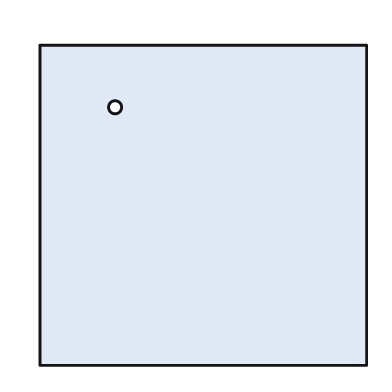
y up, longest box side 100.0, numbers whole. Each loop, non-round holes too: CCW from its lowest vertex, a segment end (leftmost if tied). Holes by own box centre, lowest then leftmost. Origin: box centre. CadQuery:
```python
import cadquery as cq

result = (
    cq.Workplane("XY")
    .moveTo(-50.0, -49.0)
    .lineTo(50.0, -49.0)
    .lineTo(50.0, 49.0)
    .lineTo(-50.0, 49.0)
    .close()
    .moveTo(-27.0, 30.0)
    .circle(2.0)
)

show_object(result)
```